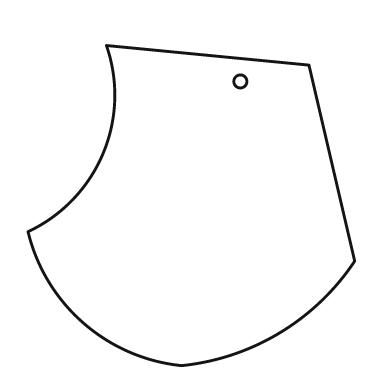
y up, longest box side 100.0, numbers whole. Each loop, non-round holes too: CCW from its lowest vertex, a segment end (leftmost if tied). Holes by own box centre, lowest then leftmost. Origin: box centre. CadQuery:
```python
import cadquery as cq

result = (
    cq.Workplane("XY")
    .moveTo(-3.0, -49.0)
    .threePointArc((27.0, -39.0), (50.0, -17.0))
    .lineTo(36.0, 43.0)
    .lineTo(-26.0, 49.0)
    .threePointArc((-27.0, 16.0), (-50.0, -8.0))
    .threePointArc((-33.0, -36.0), (-3.0, -49.0))
    .close()
    .moveTo(15.0, 38.0)
    .circle(2.0)
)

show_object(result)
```